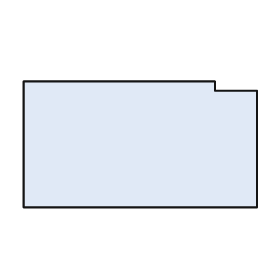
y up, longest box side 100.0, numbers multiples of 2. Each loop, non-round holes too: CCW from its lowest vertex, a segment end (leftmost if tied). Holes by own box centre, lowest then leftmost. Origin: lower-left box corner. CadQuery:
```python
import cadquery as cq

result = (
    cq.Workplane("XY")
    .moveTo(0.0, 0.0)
    .lineTo(100.0, 0.0)
    .lineTo(100.0, 50.0)
    .lineTo(82.0, 50.0)
    .lineTo(82.0, 54.0)
    .lineTo(0.0, 54.0)
    .close()
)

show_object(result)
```